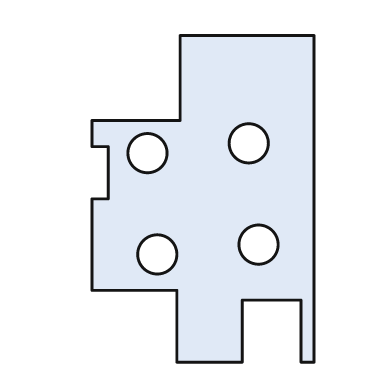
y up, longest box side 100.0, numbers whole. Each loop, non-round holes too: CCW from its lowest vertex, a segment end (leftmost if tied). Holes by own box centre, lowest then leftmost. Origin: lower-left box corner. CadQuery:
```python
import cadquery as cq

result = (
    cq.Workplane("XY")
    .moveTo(26.0, 0.0)
    .lineTo(46.0, 0.0)
    .lineTo(46.0, 19.0)
    .lineTo(64.0, 19.0)
    .lineTo(64.0, 0.0)
    .lineTo(68.0, 0.0)
    .lineTo(68.0, 100.0)
    .lineTo(27.0, 100.0)
    .lineTo(27.0, 74.0)
    .lineTo(0.0, 74.0)
    .lineTo(0.0, 66.0)
    .lineTo(5.0, 66.0)
    .lineTo(5.0, 50.0)
    .lineTo(0.0, 50.0)
    .lineTo(0.0, 22.0)
    .lineTo(26.0, 22.0)
    .close()
    .moveTo(20.0, 33.0)
    .circle(6.0)
    .moveTo(51.0, 36.0)
    .circle(6.0)
    .moveTo(17.0, 64.0)
    .circle(6.0)
    .moveTo(48.0, 67.0)
    .circle(6.0)
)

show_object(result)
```